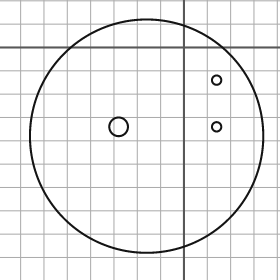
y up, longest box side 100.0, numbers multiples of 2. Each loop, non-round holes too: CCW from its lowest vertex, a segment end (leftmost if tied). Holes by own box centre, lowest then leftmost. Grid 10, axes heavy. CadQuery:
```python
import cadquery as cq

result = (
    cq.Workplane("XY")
    .moveTo(-16.0, -38.0)
    .circle(50.0)
    .moveTo(-28.0, -34.0)
    .circle(4.0)
    .moveTo(14.0, -34.0)
    .circle(2.0)
    .moveTo(14.0, -14.0)
    .circle(2.0)
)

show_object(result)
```